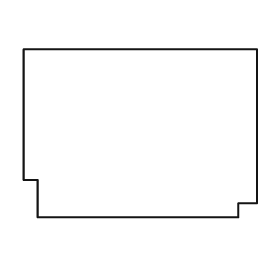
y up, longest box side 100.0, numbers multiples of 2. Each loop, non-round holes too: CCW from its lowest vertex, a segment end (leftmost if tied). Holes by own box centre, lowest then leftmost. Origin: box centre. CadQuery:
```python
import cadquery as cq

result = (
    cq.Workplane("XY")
    .moveTo(-44.0, -36.0)
    .lineTo(42.0, -36.0)
    .lineTo(42.0, -30.0)
    .lineTo(50.0, -30.0)
    .lineTo(50.0, 36.0)
    .lineTo(-50.0, 36.0)
    .lineTo(-50.0, -20.0)
    .lineTo(-44.0, -20.0)
    .close()
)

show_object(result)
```